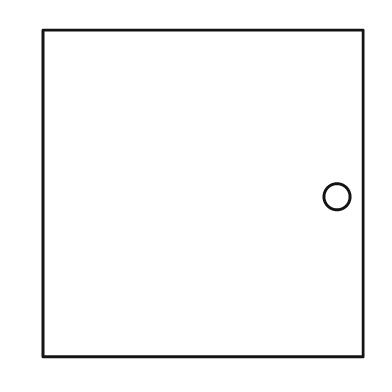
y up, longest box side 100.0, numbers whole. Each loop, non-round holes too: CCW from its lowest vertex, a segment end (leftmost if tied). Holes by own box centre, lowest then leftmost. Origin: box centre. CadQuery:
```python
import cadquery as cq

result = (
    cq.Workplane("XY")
    .moveTo(-49.0, -50.0)
    .lineTo(49.0, -50.0)
    .lineTo(49.0, 50.0)
    .lineTo(-49.0, 50.0)
    .close()
    .moveTo(41.0, -1.0)
    .circle(4.0)
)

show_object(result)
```